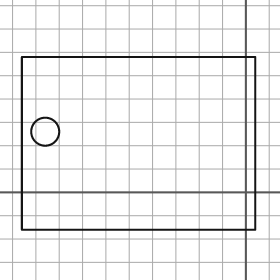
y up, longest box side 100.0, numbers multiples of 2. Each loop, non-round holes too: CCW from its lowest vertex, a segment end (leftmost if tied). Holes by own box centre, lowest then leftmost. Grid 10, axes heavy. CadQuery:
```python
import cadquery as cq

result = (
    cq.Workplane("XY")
    .moveTo(-96.0, -16.0)
    .lineTo(4.0, -16.0)
    .lineTo(4.0, 58.0)
    .lineTo(-96.0, 58.0)
    .close()
    .moveTo(-86.0, 26.0)
    .circle(6.0)
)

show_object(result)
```